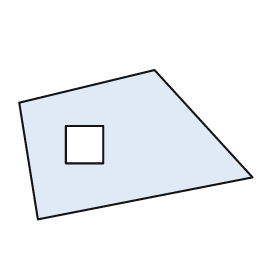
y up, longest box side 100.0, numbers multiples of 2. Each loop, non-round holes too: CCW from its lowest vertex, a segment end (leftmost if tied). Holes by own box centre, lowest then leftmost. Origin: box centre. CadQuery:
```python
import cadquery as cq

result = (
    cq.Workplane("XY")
    .moveTo(-42.0, -32.0)
    .lineTo(50.0, -14.0)
    .lineTo(8.0, 32.0)
    .lineTo(-50.0, 18.0)
    .close()
    .moveTo(-30.0, -8.0)
    .lineTo(-14.0, -8.0)
    .lineTo(-14.0, 8.0)
    .lineTo(-30.0, 8.0)
    .close()
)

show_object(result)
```